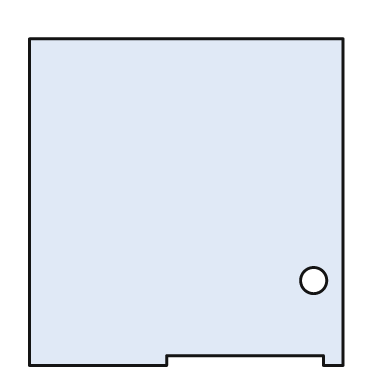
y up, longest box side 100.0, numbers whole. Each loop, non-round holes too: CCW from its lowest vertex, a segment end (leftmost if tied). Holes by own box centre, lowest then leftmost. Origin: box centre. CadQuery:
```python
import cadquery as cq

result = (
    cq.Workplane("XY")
    .moveTo(-48.0, -50.0)
    .lineTo(-6.0, -50.0)
    .lineTo(-6.0, -47.0)
    .lineTo(42.0, -47.0)
    .lineTo(42.0, -50.0)
    .lineTo(48.0, -50.0)
    .lineTo(48.0, 50.0)
    .lineTo(-48.0, 50.0)
    .close()
    .moveTo(39.0, -24.0)
    .circle(4.0)
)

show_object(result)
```